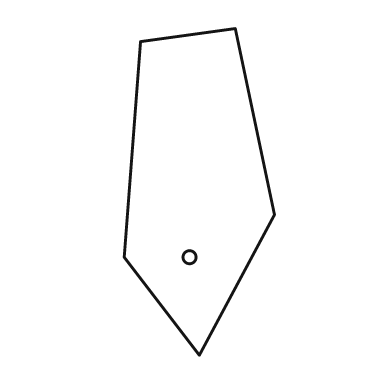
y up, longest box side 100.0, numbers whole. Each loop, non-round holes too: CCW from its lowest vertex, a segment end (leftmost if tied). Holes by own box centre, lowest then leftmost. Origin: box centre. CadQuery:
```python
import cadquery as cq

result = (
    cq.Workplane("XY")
    .moveTo(0.0, -50.0)
    .lineTo(23.0, -7.0)
    .lineTo(11.0, 50.0)
    .lineTo(-18.0, 46.0)
    .lineTo(-23.0, -20.0)
    .close()
    .moveTo(-3.0, -20.0)
    .circle(2.0)
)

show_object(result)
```